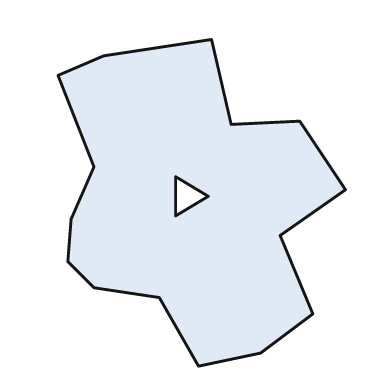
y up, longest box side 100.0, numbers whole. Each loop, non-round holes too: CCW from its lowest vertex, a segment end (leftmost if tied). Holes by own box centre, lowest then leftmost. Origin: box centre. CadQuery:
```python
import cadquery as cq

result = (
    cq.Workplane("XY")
    .moveTo(-1.0, -50.0)
    .lineTo(18.0, -46.0)
    .lineTo(34.0, -34.0)
    .lineTo(24.0, -10.0)
    .lineTo(44.0, 4.0)
    .lineTo(30.0, 25.0)
    .lineTo(9.0, 24.0)
    .lineTo(3.0, 50.0)
    .lineTo(-30.0, 45.0)
    .lineTo(-44.0, 39.0)
    .lineTo(-33.0, 11.0)
    .lineTo(-40.0, -5.0)
    .lineTo(-41.0, -18.0)
    .lineTo(-33.0, -26.0)
    .lineTo(-13.0, -29.0)
    .close()
    .moveTo(-8.0, -4.0)
    .lineTo(2.0, 2.0)
    .lineTo(-8.0, 8.0)
    .close()
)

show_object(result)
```